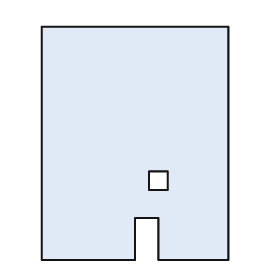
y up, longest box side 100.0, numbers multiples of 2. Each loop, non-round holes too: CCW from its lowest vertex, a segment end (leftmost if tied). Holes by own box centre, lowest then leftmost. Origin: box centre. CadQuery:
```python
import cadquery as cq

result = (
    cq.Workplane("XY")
    .moveTo(-40.0, -50.0)
    .lineTo(0.0, -50.0)
    .lineTo(0.0, -32.0)
    .lineTo(10.0, -32.0)
    .lineTo(10.0, -50.0)
    .lineTo(40.0, -50.0)
    .lineTo(40.0, 50.0)
    .lineTo(-40.0, 50.0)
    .close()
    .moveTo(6.0, -20.0)
    .lineTo(14.0, -20.0)
    .lineTo(14.0, -12.0)
    .lineTo(6.0, -12.0)
    .close()
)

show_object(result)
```